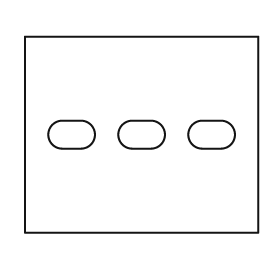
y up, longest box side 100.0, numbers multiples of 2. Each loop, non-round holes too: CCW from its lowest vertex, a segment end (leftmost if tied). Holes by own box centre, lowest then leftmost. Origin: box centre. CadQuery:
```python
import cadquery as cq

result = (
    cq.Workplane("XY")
    .moveTo(-50.0, -42.0)
    .lineTo(50.0, -42.0)
    .lineTo(50.0, 42.0)
    .lineTo(-50.0, 42.0)
    .close()
    .moveTo(-34.0, -6.0)
    .lineTo(-26.0, -6.0)
    .threePointArc((-20.0, 0.0), (-26.0, 6.0))
    .lineTo(-34.0, 6.0)
    .threePointArc((-40.0, 0.0), (-34.0, -6.0))
    .close()
    .moveTo(-4.0, -6.0)
    .lineTo(4.0, -6.0)
    .threePointArc((10.0, 0.0), (4.0, 6.0))
    .lineTo(-4.0, 6.0)
    .threePointArc((-10.0, 0.0), (-4.0, -6.0))
    .close()
    .moveTo(26.0, -6.0)
    .lineTo(34.0, -6.0)
    .threePointArc((40.0, 0.0), (34.0, 6.0))
    .lineTo(26.0, 6.0)
    .threePointArc((20.0, 0.0), (26.0, -6.0))
    .close()
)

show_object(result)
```